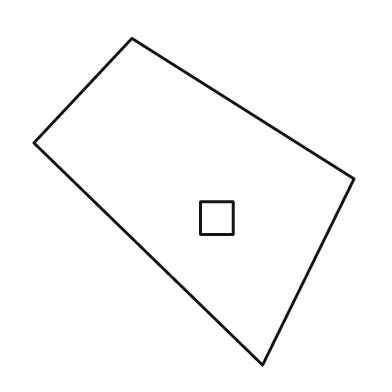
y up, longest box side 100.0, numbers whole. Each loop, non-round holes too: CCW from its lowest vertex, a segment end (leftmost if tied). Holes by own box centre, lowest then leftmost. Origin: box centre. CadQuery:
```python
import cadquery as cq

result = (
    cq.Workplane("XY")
    .moveTo(21.0, -50.0)
    .lineTo(49.0, 7.0)
    .lineTo(-19.0, 50.0)
    .lineTo(-49.0, 18.0)
    .close()
    .moveTo(2.0, -10.0)
    .lineTo(12.0, -10.0)
    .lineTo(12.0, 0.0)
    .lineTo(2.0, 0.0)
    .close()
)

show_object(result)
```